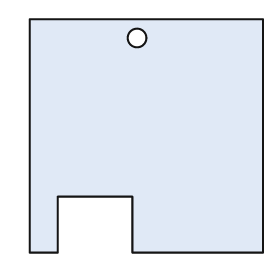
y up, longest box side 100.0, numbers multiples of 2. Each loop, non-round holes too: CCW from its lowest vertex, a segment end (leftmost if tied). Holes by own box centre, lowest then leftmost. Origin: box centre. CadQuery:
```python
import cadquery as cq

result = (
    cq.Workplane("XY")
    .moveTo(-50.0, -50.0)
    .lineTo(-38.0, -50.0)
    .lineTo(-38.0, -26.0)
    .lineTo(-6.0, -26.0)
    .lineTo(-6.0, -50.0)
    .lineTo(50.0, -50.0)
    .lineTo(50.0, 50.0)
    .lineTo(-50.0, 50.0)
    .close()
    .moveTo(-4.0, 42.0)
    .circle(4.0)
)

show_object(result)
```